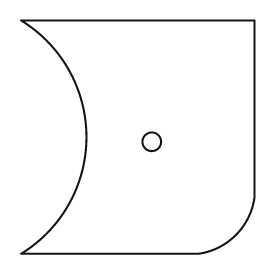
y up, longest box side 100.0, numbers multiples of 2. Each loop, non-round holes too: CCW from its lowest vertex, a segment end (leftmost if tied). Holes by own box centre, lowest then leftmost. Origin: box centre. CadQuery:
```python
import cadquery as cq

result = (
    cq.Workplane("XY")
    .moveTo(-50.0, -50.0)
    .lineTo(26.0, -50.0)
    .threePointArc((42.0, -42.0), (50.0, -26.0))
    .lineTo(50.0, 50.0)
    .lineTo(-50.0, 50.0)
    .threePointArc((-22.0, 0.0), (-50.0, -50.0))
    .close()
    .moveTo(6.0, -2.0)
    .circle(4.0)
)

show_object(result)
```